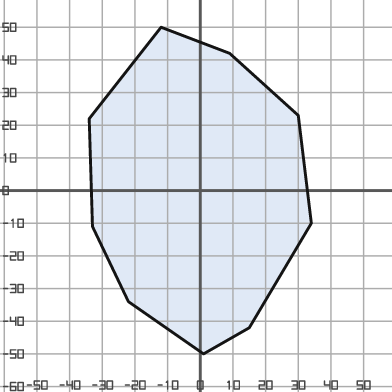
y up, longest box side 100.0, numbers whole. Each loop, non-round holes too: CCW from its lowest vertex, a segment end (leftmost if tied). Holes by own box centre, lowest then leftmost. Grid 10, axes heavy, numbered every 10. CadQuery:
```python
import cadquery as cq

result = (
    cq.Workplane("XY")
    .moveTo(1.0, -50.0)
    .lineTo(15.0, -42.0)
    .lineTo(34.0, -10.0)
    .lineTo(30.0, 23.0)
    .lineTo(9.0, 42.0)
    .lineTo(-12.0, 50.0)
    .lineTo(-34.0, 22.0)
    .lineTo(-33.0, -11.0)
    .lineTo(-22.0, -34.0)
    .close()
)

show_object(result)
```